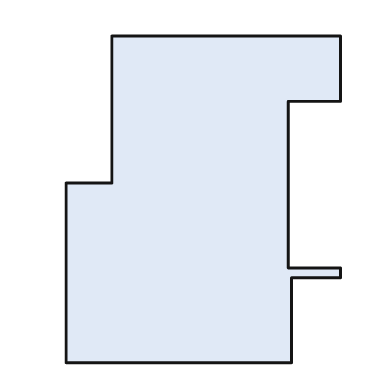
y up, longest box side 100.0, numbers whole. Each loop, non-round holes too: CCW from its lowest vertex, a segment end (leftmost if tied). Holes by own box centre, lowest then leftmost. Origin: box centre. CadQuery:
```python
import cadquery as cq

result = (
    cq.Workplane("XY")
    .moveTo(-42.0, -50.0)
    .lineTo(27.0, -50.0)
    .lineTo(27.0, -24.0)
    .lineTo(42.0, -24.0)
    .lineTo(42.0, -21.0)
    .lineTo(26.0, -21.0)
    .lineTo(26.0, 30.0)
    .lineTo(42.0, 30.0)
    .lineTo(42.0, 50.0)
    .lineTo(-28.0, 50.0)
    .lineTo(-28.0, 5.0)
    .lineTo(-42.0, 5.0)
    .close()
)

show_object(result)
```